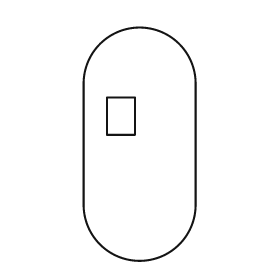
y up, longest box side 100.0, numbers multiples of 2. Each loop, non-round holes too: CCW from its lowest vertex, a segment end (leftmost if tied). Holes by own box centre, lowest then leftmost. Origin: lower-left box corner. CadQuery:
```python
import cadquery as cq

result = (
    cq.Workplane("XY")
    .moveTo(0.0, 24.0)
    .threePointArc((24.0, 0.0), (48.0, 24.0))
    .lineTo(48.0, 76.0)
    .threePointArc((24.0, 100.0), (0.0, 76.0))
    .close()
    .moveTo(10.0, 54.0)
    .lineTo(22.0, 54.0)
    .lineTo(22.0, 70.0)
    .lineTo(10.0, 70.0)
    .close()
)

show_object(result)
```